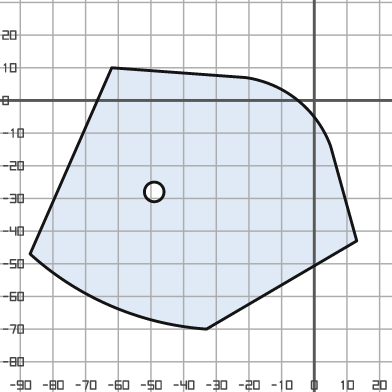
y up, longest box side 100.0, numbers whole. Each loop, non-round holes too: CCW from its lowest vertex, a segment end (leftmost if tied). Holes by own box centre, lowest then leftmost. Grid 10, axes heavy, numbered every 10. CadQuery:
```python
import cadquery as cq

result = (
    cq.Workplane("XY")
    .moveTo(-33.0, -70.0)
    .lineTo(13.0, -43.0)
    .lineTo(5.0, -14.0)
    .threePointArc((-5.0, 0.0), (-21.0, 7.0))
    .lineTo(-62.0, 10.0)
    .lineTo(-87.0, -47.0)
    .threePointArc((-62.0, -63.0), (-33.0, -70.0))
    .close()
    .moveTo(-49.0, -28.0)
    .circle(3.0)
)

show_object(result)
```